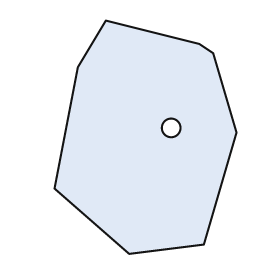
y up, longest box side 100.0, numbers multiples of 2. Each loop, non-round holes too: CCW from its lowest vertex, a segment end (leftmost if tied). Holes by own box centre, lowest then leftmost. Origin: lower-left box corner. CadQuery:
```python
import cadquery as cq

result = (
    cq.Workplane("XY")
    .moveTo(32.0, 0.0)
    .lineTo(64.0, 4.0)
    .lineTo(78.0, 52.0)
    .lineTo(68.0, 86.0)
    .lineTo(62.0, 90.0)
    .lineTo(22.0, 100.0)
    .lineTo(10.0, 80.0)
    .lineTo(0.0, 28.0)
    .close()
    .moveTo(50.0, 54.0)
    .circle(4.0)
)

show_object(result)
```